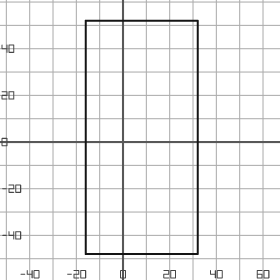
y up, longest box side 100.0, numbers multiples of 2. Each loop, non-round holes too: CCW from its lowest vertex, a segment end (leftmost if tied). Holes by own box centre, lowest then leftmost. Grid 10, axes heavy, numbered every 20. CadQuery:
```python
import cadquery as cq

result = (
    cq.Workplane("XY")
    .moveTo(-16.0, -48.0)
    .lineTo(32.0, -48.0)
    .lineTo(32.0, 52.0)
    .lineTo(-16.0, 52.0)
    .close()
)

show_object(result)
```